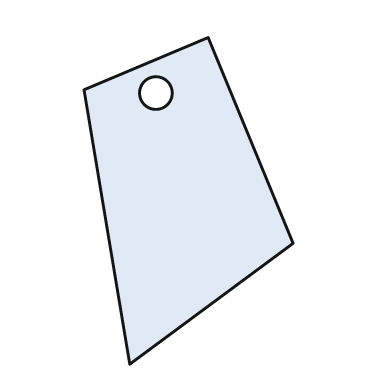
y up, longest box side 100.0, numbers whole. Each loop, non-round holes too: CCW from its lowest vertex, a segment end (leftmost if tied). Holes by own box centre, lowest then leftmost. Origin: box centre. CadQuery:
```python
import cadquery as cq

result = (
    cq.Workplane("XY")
    .moveTo(-18.0, -50.0)
    .lineTo(32.0, -13.0)
    .lineTo(6.0, 50.0)
    .lineTo(-32.0, 34.0)
    .close()
    .moveTo(-10.0, 33.0)
    .circle(5.0)
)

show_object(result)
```